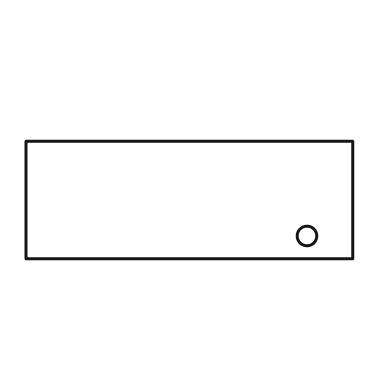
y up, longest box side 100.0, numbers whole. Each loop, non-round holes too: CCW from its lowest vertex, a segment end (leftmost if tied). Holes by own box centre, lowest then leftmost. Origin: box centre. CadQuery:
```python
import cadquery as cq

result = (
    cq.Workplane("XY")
    .moveTo(-50.0, -18.0)
    .lineTo(50.0, -18.0)
    .lineTo(50.0, 18.0)
    .lineTo(-50.0, 18.0)
    .close()
    .moveTo(36.0, -11.0)
    .circle(3.0)
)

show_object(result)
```